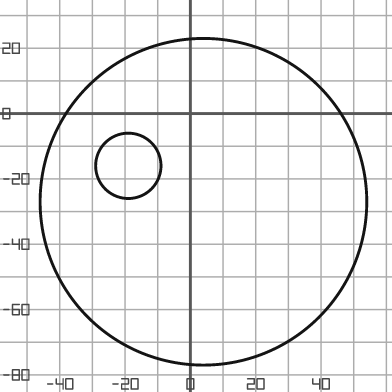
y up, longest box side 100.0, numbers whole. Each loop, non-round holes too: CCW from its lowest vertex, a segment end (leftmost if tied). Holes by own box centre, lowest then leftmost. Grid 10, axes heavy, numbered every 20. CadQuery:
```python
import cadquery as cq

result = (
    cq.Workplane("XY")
    .moveTo(4.0, -27.0)
    .circle(50.0)
    .moveTo(-19.0, -16.0)
    .circle(10.0)
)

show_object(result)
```